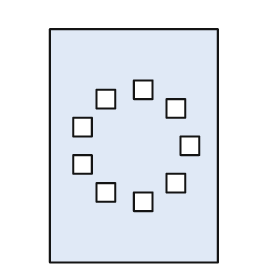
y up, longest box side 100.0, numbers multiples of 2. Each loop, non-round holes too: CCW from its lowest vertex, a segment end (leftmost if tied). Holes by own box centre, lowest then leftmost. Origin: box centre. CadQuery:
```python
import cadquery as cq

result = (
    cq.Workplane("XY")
    .moveTo(-36.0, -50.0)
    .lineTo(36.0, -50.0)
    .lineTo(36.0, 50.0)
    .lineTo(-36.0, 50.0)
    .close()
    .moveTo(0.0, -28.0)
    .lineTo(8.0, -28.0)
    .lineTo(8.0, -20.0)
    .lineTo(0.0, -20.0)
    .close()
    .moveTo(-16.0, -24.0)
    .lineTo(-8.0, -24.0)
    .lineTo(-8.0, -16.0)
    .lineTo(-16.0, -16.0)
    .close()
    .moveTo(14.0, -20.0)
    .lineTo(22.0, -20.0)
    .lineTo(22.0, -12.0)
    .lineTo(14.0, -12.0)
    .close()
    .moveTo(-26.0, -12.0)
    .lineTo(-18.0, -12.0)
    .lineTo(-18.0, -4.0)
    .lineTo(-26.0, -4.0)
    .close()
    .moveTo(20.0, -4.0)
    .lineTo(28.0, -4.0)
    .lineTo(28.0, 4.0)
    .lineTo(20.0, 4.0)
    .close()
    .moveTo(-26.0, 4.0)
    .lineTo(-18.0, 4.0)
    .lineTo(-18.0, 12.0)
    .lineTo(-26.0, 12.0)
    .close()
    .moveTo(14.0, 12.0)
    .lineTo(22.0, 12.0)
    .lineTo(22.0, 20.0)
    .lineTo(14.0, 20.0)
    .close()
    .moveTo(-16.0, 16.0)
    .lineTo(-8.0, 16.0)
    .lineTo(-8.0, 24.0)
    .lineTo(-16.0, 24.0)
    .close()
    .moveTo(0.0, 20.0)
    .lineTo(8.0, 20.0)
    .lineTo(8.0, 28.0)
    .lineTo(0.0, 28.0)
    .close()
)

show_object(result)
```